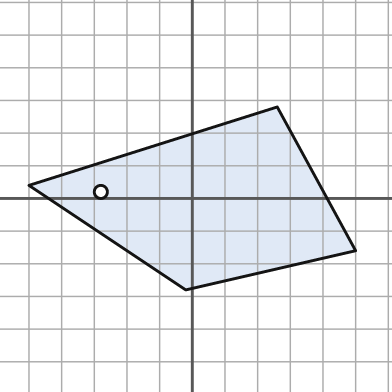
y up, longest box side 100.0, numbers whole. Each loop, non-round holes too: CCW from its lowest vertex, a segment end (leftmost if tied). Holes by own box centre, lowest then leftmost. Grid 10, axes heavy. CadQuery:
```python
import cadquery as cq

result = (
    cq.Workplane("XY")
    .moveTo(-2.0, -28.0)
    .lineTo(50.0, -16.0)
    .lineTo(26.0, 28.0)
    .lineTo(-50.0, 4.0)
    .close()
    .moveTo(-28.0, 2.0)
    .circle(2.0)
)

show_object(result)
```